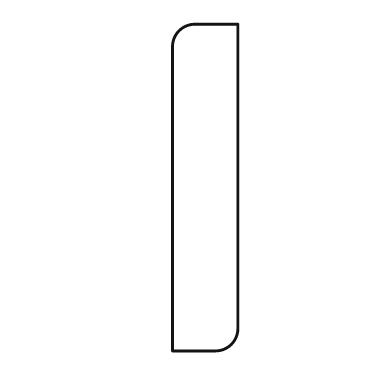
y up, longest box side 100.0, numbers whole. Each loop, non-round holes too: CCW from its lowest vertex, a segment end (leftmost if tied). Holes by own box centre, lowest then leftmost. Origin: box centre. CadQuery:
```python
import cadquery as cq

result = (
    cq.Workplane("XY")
    .moveTo(-10.0, -50.0)
    .lineTo(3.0, -50.0)
    .threePointArc((8.0, -48.0), (10.0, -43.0))
    .lineTo(10.0, 50.0)
    .lineTo(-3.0, 50.0)
    .threePointArc((-8.0, 48.0), (-10.0, 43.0))
    .close()
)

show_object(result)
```